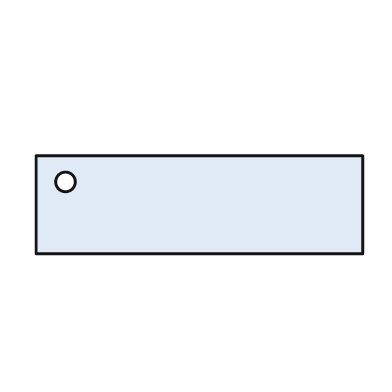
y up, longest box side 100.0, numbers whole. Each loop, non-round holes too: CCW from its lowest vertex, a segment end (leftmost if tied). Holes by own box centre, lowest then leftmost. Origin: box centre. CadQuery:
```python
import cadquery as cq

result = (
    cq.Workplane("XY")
    .moveTo(-50.0, -15.0)
    .lineTo(50.0, -15.0)
    .lineTo(50.0, 15.0)
    .lineTo(-50.0, 15.0)
    .close()
    .moveTo(-41.0, 7.0)
    .circle(3.0)
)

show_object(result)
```